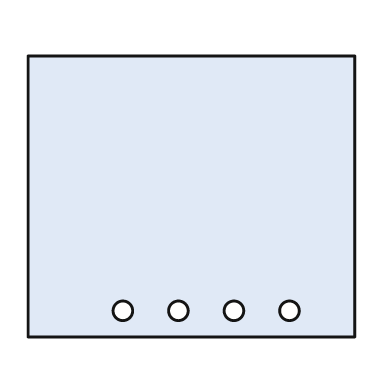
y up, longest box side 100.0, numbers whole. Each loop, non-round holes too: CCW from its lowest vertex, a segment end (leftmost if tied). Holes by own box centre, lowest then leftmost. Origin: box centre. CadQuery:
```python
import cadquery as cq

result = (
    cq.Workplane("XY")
    .moveTo(-50.0, -43.0)
    .lineTo(50.0, -43.0)
    .lineTo(50.0, 43.0)
    .lineTo(-50.0, 43.0)
    .close()
    .moveTo(-21.0, -35.0)
    .circle(3.0)
    .moveTo(-4.0, -35.0)
    .circle(3.0)
    .moveTo(13.0, -35.0)
    .circle(3.0)
    .moveTo(30.0, -35.0)
    .circle(3.0)
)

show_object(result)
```